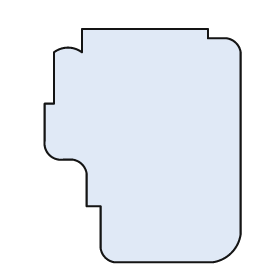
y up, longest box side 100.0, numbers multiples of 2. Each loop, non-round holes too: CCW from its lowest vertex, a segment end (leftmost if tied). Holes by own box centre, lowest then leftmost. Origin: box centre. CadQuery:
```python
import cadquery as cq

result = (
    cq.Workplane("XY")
    .moveTo(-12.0, -50.0)
    .lineTo(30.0, -50.0)
    .threePointArc((38.0, -46.0), (42.0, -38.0))
    .lineTo(42.0, 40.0)
    .threePointArc((40.0, 44.0), (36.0, 46.0))
    .lineTo(28.0, 46.0)
    .lineTo(28.0, 50.0)
    .lineTo(-26.0, 50.0)
    .lineTo(-26.0, 40.0)
    .threePointArc((-32.0, 42.0), (-38.0, 40.0))
    .lineTo(-38.0, 18.0)
    .lineTo(-42.0, 18.0)
    .lineTo(-42.0, 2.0)
    .threePointArc((-40.0, -4.0), (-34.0, -6.0))
    .lineTo(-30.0, -6.0)
    .threePointArc((-26.0, -8.0), (-24.0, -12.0))
    .lineTo(-24.0, -26.0)
    .lineTo(-18.0, -26.0)
    .lineTo(-18.0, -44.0)
    .threePointArc((-16.0, -48.0), (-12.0, -50.0))
    .close()
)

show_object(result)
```